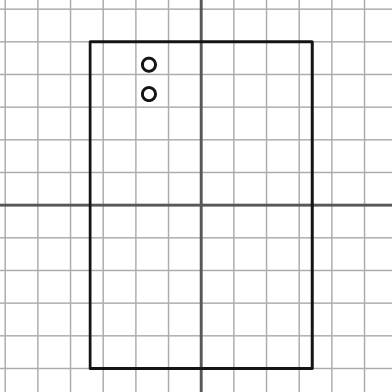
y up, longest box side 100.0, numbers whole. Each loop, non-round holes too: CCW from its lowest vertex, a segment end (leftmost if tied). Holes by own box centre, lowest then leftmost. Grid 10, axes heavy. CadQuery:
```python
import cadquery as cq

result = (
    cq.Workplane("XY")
    .moveTo(-34.0, -50.0)
    .lineTo(34.0, -50.0)
    .lineTo(34.0, 50.0)
    .lineTo(-34.0, 50.0)
    .close()
    .moveTo(-16.0, 34.0)
    .circle(2.0)
    .moveTo(-16.0, 43.0)
    .circle(2.0)
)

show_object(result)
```